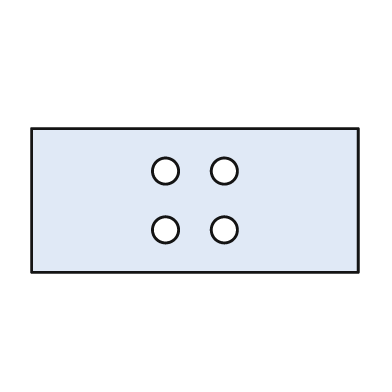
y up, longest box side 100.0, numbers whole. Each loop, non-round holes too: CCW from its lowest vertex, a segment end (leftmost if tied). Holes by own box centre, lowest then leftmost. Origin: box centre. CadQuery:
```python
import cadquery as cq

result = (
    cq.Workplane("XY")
    .moveTo(-50.0, -22.0)
    .lineTo(50.0, -22.0)
    .lineTo(50.0, 22.0)
    .lineTo(-50.0, 22.0)
    .close()
    .moveTo(-9.0, -9.0)
    .circle(4.0)
    .moveTo(9.0, -9.0)
    .circle(4.0)
    .moveTo(-9.0, 9.0)
    .circle(4.0)
    .moveTo(9.0, 9.0)
    .circle(4.0)
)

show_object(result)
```